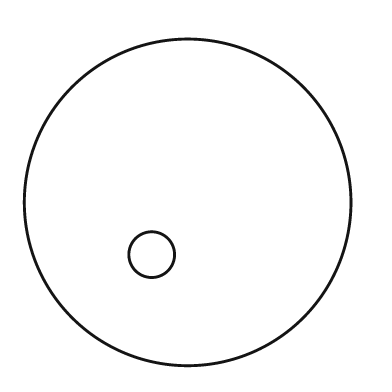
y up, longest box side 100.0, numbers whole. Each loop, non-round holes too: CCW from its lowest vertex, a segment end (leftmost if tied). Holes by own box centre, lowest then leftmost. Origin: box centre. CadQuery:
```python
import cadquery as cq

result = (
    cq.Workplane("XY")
    .moveTo(0.0, 0.0)
    .circle(50.0)
    .moveTo(-11.0, -16.0)
    .circle(7.0)
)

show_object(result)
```